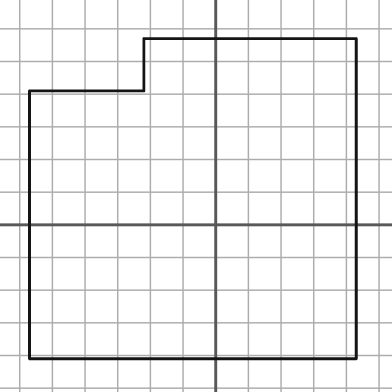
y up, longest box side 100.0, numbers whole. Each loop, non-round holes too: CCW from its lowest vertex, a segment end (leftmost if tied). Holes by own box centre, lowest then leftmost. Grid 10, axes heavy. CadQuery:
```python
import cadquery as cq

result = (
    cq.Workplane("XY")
    .moveTo(-57.0, -41.0)
    .lineTo(43.0, -41.0)
    .lineTo(43.0, 57.0)
    .lineTo(-22.0, 57.0)
    .lineTo(-22.0, 41.0)
    .lineTo(-57.0, 41.0)
    .close()
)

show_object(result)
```